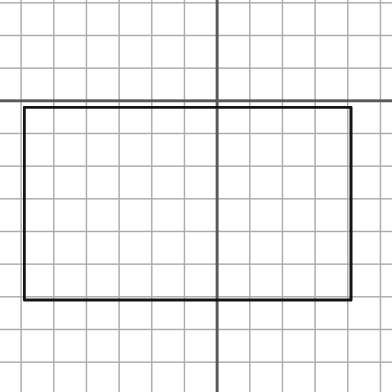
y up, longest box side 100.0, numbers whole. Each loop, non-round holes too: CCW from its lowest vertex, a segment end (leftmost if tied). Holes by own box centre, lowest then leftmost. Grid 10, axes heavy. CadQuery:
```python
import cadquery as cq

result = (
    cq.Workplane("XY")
    .moveTo(-59.0, -61.0)
    .lineTo(41.0, -61.0)
    .lineTo(41.0, -2.0)
    .lineTo(-59.0, -2.0)
    .close()
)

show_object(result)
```